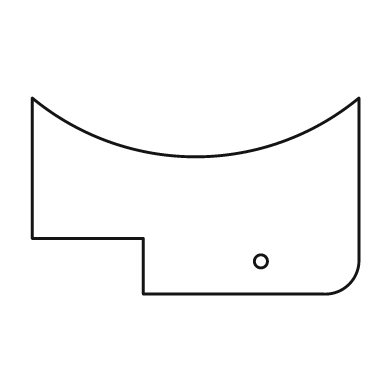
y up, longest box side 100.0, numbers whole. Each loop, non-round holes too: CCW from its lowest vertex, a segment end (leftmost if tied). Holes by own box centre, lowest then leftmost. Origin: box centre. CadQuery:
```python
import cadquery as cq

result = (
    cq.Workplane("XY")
    .moveTo(-16.0, -30.0)
    .lineTo(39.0, -30.0)
    .threePointArc((47.0, -27.0), (50.0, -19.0))
    .lineTo(50.0, 30.0)
    .threePointArc((0.0, 12.0), (-50.0, 30.0))
    .lineTo(-50.0, -13.0)
    .lineTo(-16.0, -13.0)
    .close()
    .moveTo(20.0, -20.0)
    .circle(2.0)
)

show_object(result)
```